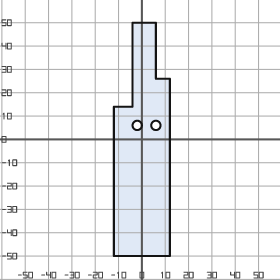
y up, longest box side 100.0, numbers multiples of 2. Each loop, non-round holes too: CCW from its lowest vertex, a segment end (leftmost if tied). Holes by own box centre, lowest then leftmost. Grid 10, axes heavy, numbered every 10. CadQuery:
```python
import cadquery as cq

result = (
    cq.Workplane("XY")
    .moveTo(-12.0, -50.0)
    .lineTo(12.0, -50.0)
    .lineTo(12.0, 26.0)
    .lineTo(6.0, 26.0)
    .lineTo(6.0, 50.0)
    .lineTo(-4.0, 50.0)
    .lineTo(-4.0, 14.0)
    .lineTo(-12.0, 14.0)
    .close()
    .moveTo(-2.0, 6.0)
    .circle(2.0)
    .moveTo(6.0, 6.0)
    .circle(2.0)
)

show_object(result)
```